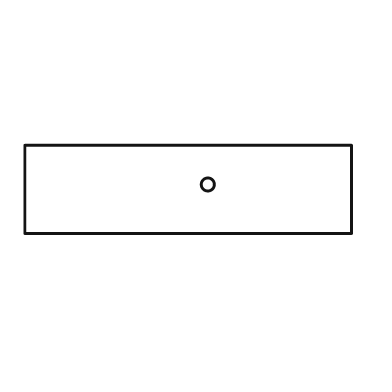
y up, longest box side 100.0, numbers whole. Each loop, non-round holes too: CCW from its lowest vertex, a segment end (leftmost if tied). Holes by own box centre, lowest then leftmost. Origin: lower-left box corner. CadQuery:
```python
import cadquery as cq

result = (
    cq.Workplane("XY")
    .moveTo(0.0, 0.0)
    .lineTo(100.0, 0.0)
    .lineTo(100.0, 27.0)
    .lineTo(0.0, 27.0)
    .close()
    .moveTo(56.0, 15.0)
    .circle(2.0)
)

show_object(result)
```